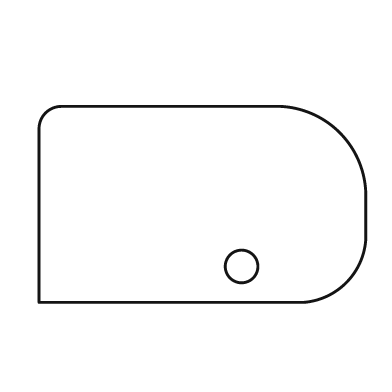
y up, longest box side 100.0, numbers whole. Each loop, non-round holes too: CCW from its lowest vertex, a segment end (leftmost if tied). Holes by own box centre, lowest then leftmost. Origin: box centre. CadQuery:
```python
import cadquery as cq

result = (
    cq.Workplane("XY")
    .moveTo(-50.0, -30.0)
    .lineTo(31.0, -30.0)
    .threePointArc((44.0, -24.0), (50.0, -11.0))
    .lineTo(50.0, 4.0)
    .threePointArc((42.0, 22.0), (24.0, 30.0))
    .lineTo(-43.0, 30.0)
    .threePointArc((-48.0, 28.0), (-50.0, 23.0))
    .close()
    .moveTo(12.0, -19.0)
    .circle(5.0)
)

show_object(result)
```